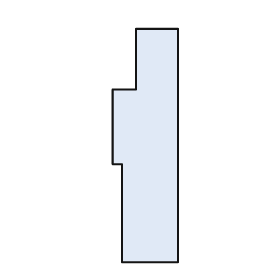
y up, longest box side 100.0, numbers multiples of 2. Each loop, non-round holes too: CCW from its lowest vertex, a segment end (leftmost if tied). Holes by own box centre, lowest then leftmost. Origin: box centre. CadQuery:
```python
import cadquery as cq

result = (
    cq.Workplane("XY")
    .moveTo(-10.0, -50.0)
    .lineTo(14.0, -50.0)
    .lineTo(14.0, 50.0)
    .lineTo(-4.0, 50.0)
    .lineTo(-4.0, 24.0)
    .lineTo(-14.0, 24.0)
    .lineTo(-14.0, -8.0)
    .lineTo(-10.0, -8.0)
    .close()
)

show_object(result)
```